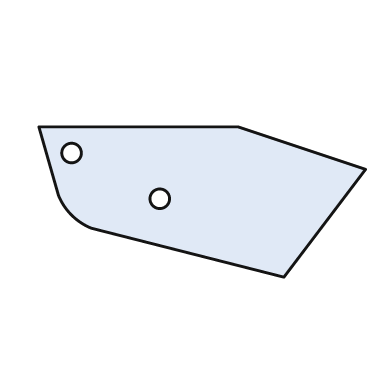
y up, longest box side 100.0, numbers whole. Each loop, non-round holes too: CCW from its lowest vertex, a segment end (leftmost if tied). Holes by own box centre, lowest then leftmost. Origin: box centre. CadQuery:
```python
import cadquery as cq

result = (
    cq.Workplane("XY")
    .moveTo(25.0, -23.0)
    .lineTo(50.0, 10.0)
    .lineTo(11.0, 23.0)
    .lineTo(-50.0, 23.0)
    .lineTo(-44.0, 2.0)
    .threePointArc((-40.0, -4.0), (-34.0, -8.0))
    .close()
    .moveTo(-13.0, 1.0)
    .circle(3.0)
    .moveTo(-40.0, 15.0)
    .circle(3.0)
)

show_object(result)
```